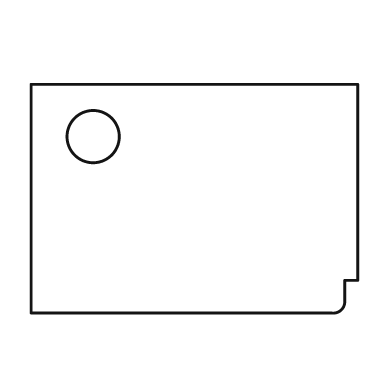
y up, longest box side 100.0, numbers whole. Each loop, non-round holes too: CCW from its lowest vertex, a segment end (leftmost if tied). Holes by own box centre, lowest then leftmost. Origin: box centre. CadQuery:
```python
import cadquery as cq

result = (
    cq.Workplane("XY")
    .moveTo(-50.0, -35.0)
    .lineTo(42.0, -35.0)
    .threePointArc((45.0, -34.0), (46.0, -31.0))
    .lineTo(46.0, -25.0)
    .lineTo(50.0, -25.0)
    .lineTo(50.0, 35.0)
    .lineTo(-50.0, 35.0)
    .close()
    .moveTo(-31.0, 19.0)
    .circle(8.0)
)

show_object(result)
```